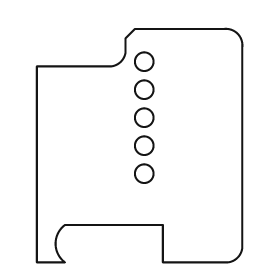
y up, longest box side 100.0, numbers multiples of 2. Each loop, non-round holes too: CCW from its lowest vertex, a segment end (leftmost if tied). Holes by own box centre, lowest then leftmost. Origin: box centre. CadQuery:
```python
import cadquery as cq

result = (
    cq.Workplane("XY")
    .moveTo(-44.0, -50.0)
    .lineTo(-32.0, -50.0)
    .threePointArc((-36.0, -42.0), (-32.0, -34.0))
    .lineTo(10.0, -34.0)
    .lineTo(10.0, -50.0)
    .lineTo(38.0, -50.0)
    .threePointArc((42.0, -48.0), (44.0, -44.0))
    .lineTo(44.0, 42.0)
    .threePointArc((42.0, 48.0), (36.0, 50.0))
    .lineTo(-2.0, 50.0)
    .lineTo(-6.0, 46.0)
    .lineTo(-6.0, 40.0)
    .threePointArc((-8.0, 36.0), (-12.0, 34.0))
    .lineTo(-44.0, 34.0)
    .close()
    .moveTo(2.0, -12.0)
    .circle(4.0)
    .moveTo(2.0, 0.0)
    .circle(4.0)
    .moveTo(2.0, 12.0)
    .circle(4.0)
    .moveTo(2.0, 24.0)
    .circle(4.0)
    .moveTo(2.0, 36.0)
    .circle(4.0)
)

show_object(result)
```